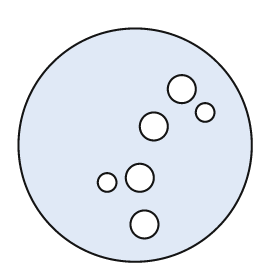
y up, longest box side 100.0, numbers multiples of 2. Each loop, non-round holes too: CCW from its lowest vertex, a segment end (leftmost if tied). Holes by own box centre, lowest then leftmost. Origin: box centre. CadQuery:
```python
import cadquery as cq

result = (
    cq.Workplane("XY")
    .moveTo(0.0, 0.0)
    .circle(50.0)
    .moveTo(4.0, -34.0)
    .circle(6.0)
    .moveTo(-12.0, -16.0)
    .circle(4.0)
    .moveTo(2.0, -14.0)
    .circle(6.0)
    .moveTo(8.0, 8.0)
    .circle(6.0)
    .moveTo(30.0, 14.0)
    .circle(4.0)
    .moveTo(20.0, 24.0)
    .circle(6.0)
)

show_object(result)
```